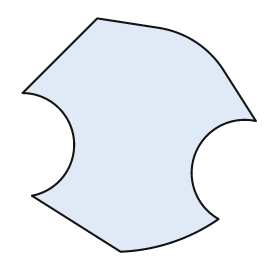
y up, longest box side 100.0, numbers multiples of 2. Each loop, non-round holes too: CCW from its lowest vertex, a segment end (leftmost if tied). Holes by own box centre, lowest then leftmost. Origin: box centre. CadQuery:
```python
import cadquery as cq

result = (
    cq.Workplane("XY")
    .moveTo(-8.0, -50.0)
    .threePointArc((14.0, -46.0), (34.0, -36.0))
    .threePointArc((24.0, -8.0), (50.0, 6.0))
    .lineTo(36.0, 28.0)
    .threePointArc((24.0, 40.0), (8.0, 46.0))
    .lineTo(-18.0, 50.0)
    .lineTo(-50.0, 18.0)
    .threePointArc((-28.0, -2.0), (-46.0, -26.0))
    .close()
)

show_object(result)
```